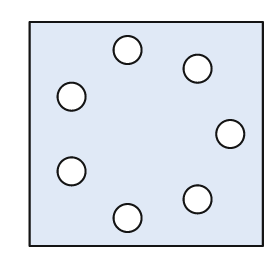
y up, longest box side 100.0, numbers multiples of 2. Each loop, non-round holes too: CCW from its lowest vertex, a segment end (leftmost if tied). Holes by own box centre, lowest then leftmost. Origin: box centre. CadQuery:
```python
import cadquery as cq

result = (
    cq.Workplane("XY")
    .moveTo(-50.0, -48.0)
    .lineTo(50.0, -48.0)
    .lineTo(50.0, 48.0)
    .lineTo(-50.0, 48.0)
    .close()
    .moveTo(-8.0, -36.0)
    .circle(6.0)
    .moveTo(22.0, -28.0)
    .circle(6.0)
    .moveTo(-32.0, -16.0)
    .circle(6.0)
    .moveTo(36.0, 0.0)
    .circle(6.0)
    .moveTo(-32.0, 16.0)
    .circle(6.0)
    .moveTo(22.0, 28.0)
    .circle(6.0)
    .moveTo(-8.0, 36.0)
    .circle(6.0)
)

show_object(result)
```